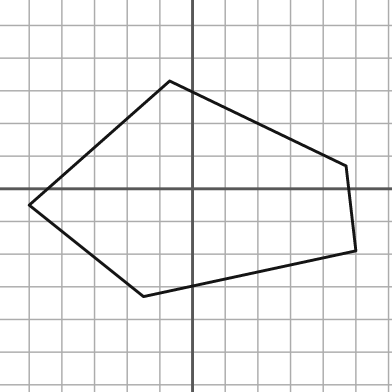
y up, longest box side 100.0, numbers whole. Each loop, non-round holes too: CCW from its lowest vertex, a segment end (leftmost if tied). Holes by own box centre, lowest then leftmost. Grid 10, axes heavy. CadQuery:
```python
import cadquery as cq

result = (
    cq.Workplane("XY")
    .moveTo(-15.0, -33.0)
    .lineTo(50.0, -19.0)
    .lineTo(47.0, 7.0)
    .lineTo(-7.0, 33.0)
    .lineTo(-50.0, -5.0)
    .close()
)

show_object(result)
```